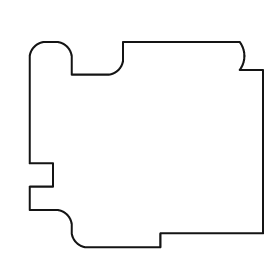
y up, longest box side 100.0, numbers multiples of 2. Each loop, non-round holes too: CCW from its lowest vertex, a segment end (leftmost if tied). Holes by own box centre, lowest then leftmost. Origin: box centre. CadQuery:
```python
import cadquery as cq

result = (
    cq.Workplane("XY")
    .moveTo(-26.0, -44.0)
    .lineTo(6.0, -44.0)
    .lineTo(6.0, -38.0)
    .lineTo(50.0, -38.0)
    .lineTo(50.0, 32.0)
    .lineTo(40.0, 32.0)
    .threePointArc((42.0, 38.0), (40.0, 44.0))
    .lineTo(-10.0, 44.0)
    .lineTo(-10.0, 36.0)
    .threePointArc((-12.0, 32.0), (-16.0, 30.0))
    .lineTo(-32.0, 30.0)
    .lineTo(-32.0, 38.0)
    .threePointArc((-34.0, 42.0), (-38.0, 44.0))
    .lineTo(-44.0, 44.0)
    .threePointArc((-48.0, 42.0), (-50.0, 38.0))
    .lineTo(-50.0, -8.0)
    .lineTo(-40.0, -8.0)
    .lineTo(-40.0, -18.0)
    .lineTo(-50.0, -18.0)
    .lineTo(-50.0, -28.0)
    .lineTo(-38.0, -28.0)
    .threePointArc((-34.0, -30.0), (-32.0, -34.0))
    .lineTo(-32.0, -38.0)
    .threePointArc((-30.0, -42.0), (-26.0, -44.0))
    .close()
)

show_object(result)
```